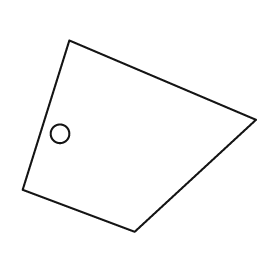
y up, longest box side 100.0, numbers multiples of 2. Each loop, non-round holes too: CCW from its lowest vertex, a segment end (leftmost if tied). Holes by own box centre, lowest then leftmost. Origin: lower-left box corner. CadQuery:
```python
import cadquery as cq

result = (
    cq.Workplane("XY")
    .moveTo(48.0, 0.0)
    .lineTo(100.0, 48.0)
    .lineTo(20.0, 82.0)
    .lineTo(0.0, 18.0)
    .close()
    .moveTo(16.0, 42.0)
    .circle(4.0)
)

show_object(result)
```